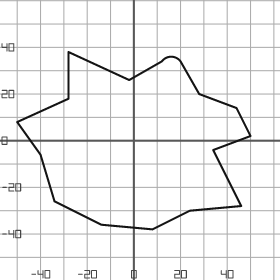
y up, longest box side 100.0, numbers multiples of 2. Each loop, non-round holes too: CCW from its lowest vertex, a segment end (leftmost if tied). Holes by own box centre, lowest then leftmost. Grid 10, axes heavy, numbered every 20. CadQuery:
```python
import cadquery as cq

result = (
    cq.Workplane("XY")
    .moveTo(8.0, -38.0)
    .lineTo(24.0, -30.0)
    .lineTo(46.0, -28.0)
    .lineTo(34.0, -4.0)
    .lineTo(50.0, 2.0)
    .lineTo(44.0, 14.0)
    .lineTo(28.0, 20.0)
    .lineTo(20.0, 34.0)
    .threePointArc((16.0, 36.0), (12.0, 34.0))
    .lineTo(-2.0, 26.0)
    .lineTo(-28.0, 38.0)
    .lineTo(-28.0, 18.0)
    .lineTo(-50.0, 8.0)
    .lineTo(-40.0, -6.0)
    .lineTo(-34.0, -26.0)
    .lineTo(-14.0, -36.0)
    .close()
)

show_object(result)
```